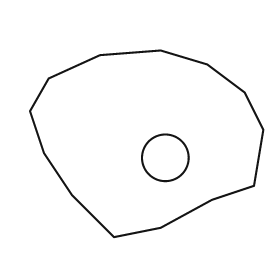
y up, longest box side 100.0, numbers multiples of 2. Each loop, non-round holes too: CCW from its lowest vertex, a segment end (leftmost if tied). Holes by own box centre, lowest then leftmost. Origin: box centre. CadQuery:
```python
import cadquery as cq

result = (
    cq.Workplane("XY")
    .moveTo(-14.0, -40.0)
    .lineTo(6.0, -36.0)
    .lineTo(28.0, -24.0)
    .lineTo(46.0, -18.0)
    .lineTo(50.0, 6.0)
    .lineTo(42.0, 22.0)
    .lineTo(26.0, 34.0)
    .lineTo(6.0, 40.0)
    .lineTo(-20.0, 38.0)
    .lineTo(-42.0, 28.0)
    .lineTo(-50.0, 14.0)
    .lineTo(-44.0, -4.0)
    .lineTo(-32.0, -22.0)
    .close()
    .moveTo(8.0, -6.0)
    .circle(10.0)
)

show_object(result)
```